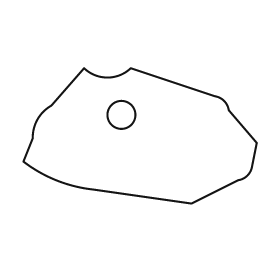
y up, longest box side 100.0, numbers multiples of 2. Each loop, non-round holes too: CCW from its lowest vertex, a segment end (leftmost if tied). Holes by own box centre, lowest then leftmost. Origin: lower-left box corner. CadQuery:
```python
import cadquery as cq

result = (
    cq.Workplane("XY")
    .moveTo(72.0, 0.0)
    .lineTo(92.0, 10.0)
    .threePointArc((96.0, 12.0), (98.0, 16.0))
    .lineTo(100.0, 26.0)
    .lineTo(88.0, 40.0)
    .threePointArc((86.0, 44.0), (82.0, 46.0))
    .lineTo(46.0, 58.0)
    .threePointArc((36.0, 54.0), (26.0, 58.0))
    .lineTo(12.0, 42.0)
    .threePointArc((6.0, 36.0), (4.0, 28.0))
    .lineTo(0.0, 18.0)
    .threePointArc((14.0, 10.0), (30.0, 6.0))
    .close()
    .moveTo(42.0, 38.0)
    .circle(6.0)
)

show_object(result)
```